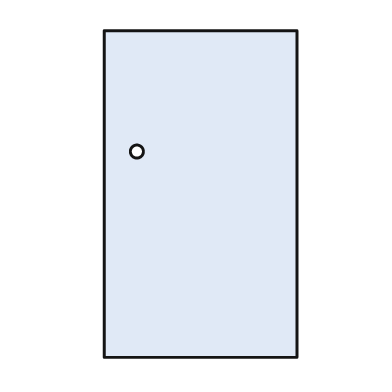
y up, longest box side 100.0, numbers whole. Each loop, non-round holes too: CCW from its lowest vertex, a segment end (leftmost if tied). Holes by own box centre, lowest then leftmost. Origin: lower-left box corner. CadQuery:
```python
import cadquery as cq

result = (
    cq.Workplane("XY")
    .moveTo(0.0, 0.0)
    .lineTo(59.0, 0.0)
    .lineTo(59.0, 100.0)
    .lineTo(0.0, 100.0)
    .close()
    .moveTo(10.0, 63.0)
    .circle(2.0)
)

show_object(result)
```